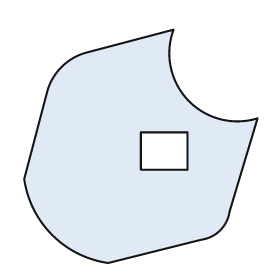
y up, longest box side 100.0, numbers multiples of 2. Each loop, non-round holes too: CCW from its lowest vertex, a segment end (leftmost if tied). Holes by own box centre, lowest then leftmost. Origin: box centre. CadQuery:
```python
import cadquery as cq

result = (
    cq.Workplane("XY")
    .moveTo(-14.0, -50.0)
    .lineTo(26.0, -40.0)
    .threePointArc((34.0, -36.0), (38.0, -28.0))
    .lineTo(50.0, 12.0)
    .threePointArc((20.0, 20.0), (14.0, 50.0))
    .lineTo(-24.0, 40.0)
    .threePointArc((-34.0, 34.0), (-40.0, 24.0))
    .lineTo(-50.0, -14.0)
    .threePointArc((-38.0, -38.0), (-14.0, -50.0))
    .close()
    .moveTo(0.0, -10.0)
    .lineTo(20.0, -10.0)
    .lineTo(20.0, 6.0)
    .lineTo(0.0, 6.0)
    .close()
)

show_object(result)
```